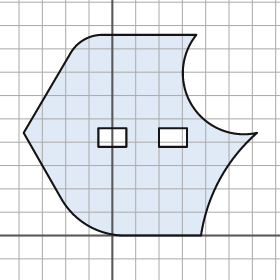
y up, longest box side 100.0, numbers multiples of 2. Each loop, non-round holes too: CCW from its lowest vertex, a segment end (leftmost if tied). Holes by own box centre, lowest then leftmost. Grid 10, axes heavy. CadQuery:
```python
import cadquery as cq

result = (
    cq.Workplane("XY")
    .moveTo(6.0, 0.0)
    .lineTo(38.0, 0.0)
    .threePointArc((46.0, 24.0), (62.0, 44.0))
    .threePointArc((34.0, 56.0), (36.0, 86.0))
    .lineTo(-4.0, 86.0)
    .threePointArc((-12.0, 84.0), (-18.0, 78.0))
    .lineTo(-38.0, 44.0)
    .lineTo(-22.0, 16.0)
    .threePointArc((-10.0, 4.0), (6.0, 0.0))
    .close()
    .moveTo(-6.0, 38.0)
    .lineTo(6.0, 38.0)
    .lineTo(6.0, 46.0)
    .lineTo(-6.0, 46.0)
    .close()
    .moveTo(20.0, 38.0)
    .lineTo(32.0, 38.0)
    .lineTo(32.0, 46.0)
    .lineTo(20.0, 46.0)
    .close()
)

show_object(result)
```